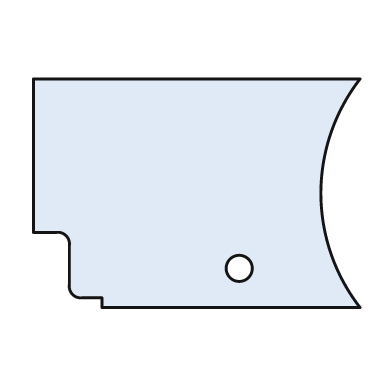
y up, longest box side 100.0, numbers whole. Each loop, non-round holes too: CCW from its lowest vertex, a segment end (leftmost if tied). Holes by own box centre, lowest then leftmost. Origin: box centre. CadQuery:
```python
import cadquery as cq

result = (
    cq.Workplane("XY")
    .moveTo(-29.0, -35.0)
    .lineTo(50.0, -35.0)
    .threePointArc((38.0, 0.0), (50.0, 35.0))
    .lineTo(-50.0, 35.0)
    .lineTo(-50.0, -12.0)
    .lineTo(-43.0, -12.0)
    .threePointArc((-40.0, -13.0), (-39.0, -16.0))
    .lineTo(-39.0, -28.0)
    .threePointArc((-38.0, -31.0), (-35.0, -32.0))
    .lineTo(-29.0, -32.0)
    .close()
    .moveTo(13.0, -23.0)
    .circle(4.0)
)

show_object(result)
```